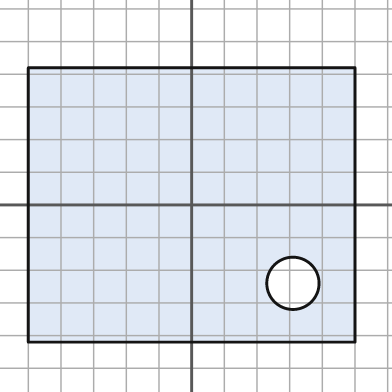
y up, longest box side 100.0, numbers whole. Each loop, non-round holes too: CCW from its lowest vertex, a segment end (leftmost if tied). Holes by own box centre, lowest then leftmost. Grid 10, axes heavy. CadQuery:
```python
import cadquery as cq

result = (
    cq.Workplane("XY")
    .moveTo(-50.0, -42.0)
    .lineTo(50.0, -42.0)
    .lineTo(50.0, 42.0)
    .lineTo(-50.0, 42.0)
    .close()
    .moveTo(31.0, -24.0)
    .circle(8.0)
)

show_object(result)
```